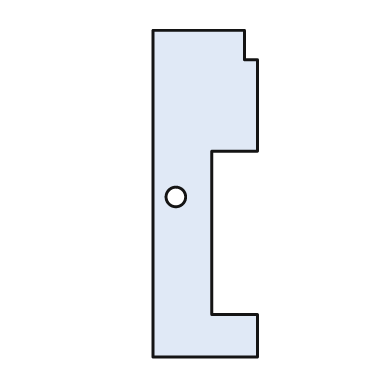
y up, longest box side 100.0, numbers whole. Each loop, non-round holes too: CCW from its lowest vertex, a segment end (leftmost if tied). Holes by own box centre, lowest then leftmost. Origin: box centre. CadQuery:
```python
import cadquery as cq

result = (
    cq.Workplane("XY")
    .moveTo(-16.0, -50.0)
    .lineTo(16.0, -50.0)
    .lineTo(16.0, -37.0)
    .lineTo(2.0, -37.0)
    .lineTo(2.0, 13.0)
    .lineTo(16.0, 13.0)
    .lineTo(16.0, 41.0)
    .lineTo(12.0, 41.0)
    .lineTo(12.0, 50.0)
    .lineTo(-16.0, 50.0)
    .close()
    .moveTo(-9.0, -1.0)
    .circle(3.0)
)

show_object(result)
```